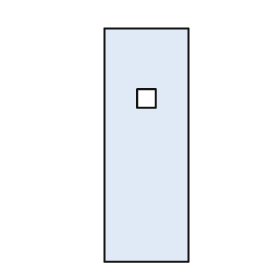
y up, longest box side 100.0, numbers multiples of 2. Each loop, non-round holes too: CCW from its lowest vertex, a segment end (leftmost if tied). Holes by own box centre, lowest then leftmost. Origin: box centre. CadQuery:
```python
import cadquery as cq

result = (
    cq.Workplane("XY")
    .moveTo(-18.0, -50.0)
    .lineTo(18.0, -50.0)
    .lineTo(18.0, 50.0)
    .lineTo(-18.0, 50.0)
    .close()
    .moveTo(-4.0, 16.0)
    .lineTo(4.0, 16.0)
    .lineTo(4.0, 24.0)
    .lineTo(-4.0, 24.0)
    .close()
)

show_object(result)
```